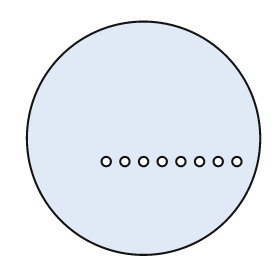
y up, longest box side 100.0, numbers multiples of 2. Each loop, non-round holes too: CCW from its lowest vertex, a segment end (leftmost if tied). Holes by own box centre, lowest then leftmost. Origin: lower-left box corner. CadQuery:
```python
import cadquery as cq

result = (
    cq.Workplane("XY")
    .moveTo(50.0, 50.0)
    .circle(50.0)
    .moveTo(34.0, 40.0)
    .circle(2.0)
    .moveTo(42.0, 40.0)
    .circle(2.0)
    .moveTo(50.0, 40.0)
    .circle(2.0)
    .moveTo(58.0, 40.0)
    .circle(2.0)
    .moveTo(66.0, 40.0)
    .circle(2.0)
    .moveTo(74.0, 40.0)
    .circle(2.0)
    .moveTo(82.0, 40.0)
    .circle(2.0)
    .moveTo(90.0, 40.0)
    .circle(2.0)
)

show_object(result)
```